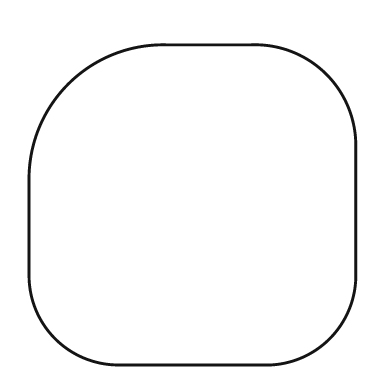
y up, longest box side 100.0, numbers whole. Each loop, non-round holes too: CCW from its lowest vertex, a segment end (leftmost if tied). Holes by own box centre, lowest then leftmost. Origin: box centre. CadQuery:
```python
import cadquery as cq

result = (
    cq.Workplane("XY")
    .moveTo(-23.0, -49.0)
    .lineTo(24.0, -49.0)
    .threePointArc((42.0, -41.0), (50.0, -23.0))
    .lineTo(50.0, 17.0)
    .threePointArc((41.0, 40.0), (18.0, 49.0))
    .lineTo(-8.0, 49.0)
    .threePointArc((-38.0, 37.0), (-50.0, 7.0))
    .lineTo(-50.0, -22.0)
    .threePointArc((-42.0, -41.0), (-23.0, -49.0))
    .close()
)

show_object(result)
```